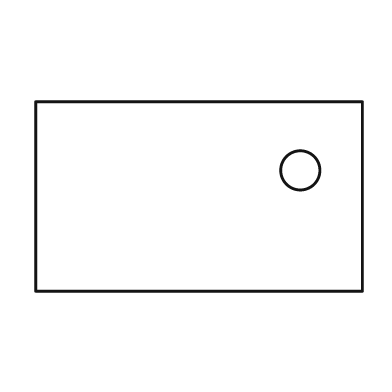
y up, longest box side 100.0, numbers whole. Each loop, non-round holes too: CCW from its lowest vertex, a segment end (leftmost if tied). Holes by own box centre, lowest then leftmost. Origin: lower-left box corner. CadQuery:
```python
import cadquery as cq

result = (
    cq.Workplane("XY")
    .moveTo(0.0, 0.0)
    .lineTo(100.0, 0.0)
    .lineTo(100.0, 58.0)
    .lineTo(0.0, 58.0)
    .close()
    .moveTo(81.0, 37.0)
    .circle(6.0)
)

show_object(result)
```